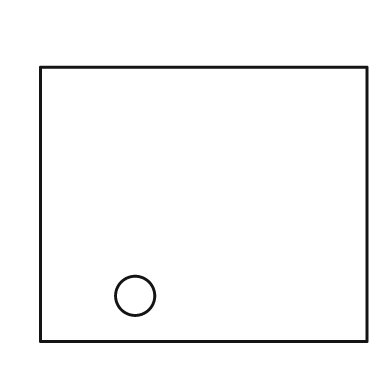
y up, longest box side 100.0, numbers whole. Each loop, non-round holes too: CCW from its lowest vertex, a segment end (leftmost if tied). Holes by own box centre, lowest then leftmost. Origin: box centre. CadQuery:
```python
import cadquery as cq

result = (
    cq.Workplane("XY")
    .moveTo(-50.0, -42.0)
    .lineTo(50.0, -42.0)
    .lineTo(50.0, 42.0)
    .lineTo(-50.0, 42.0)
    .close()
    .moveTo(-21.0, -28.0)
    .circle(6.0)
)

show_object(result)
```